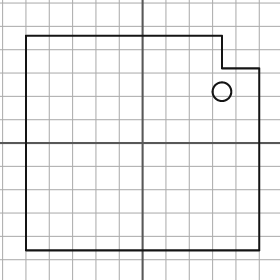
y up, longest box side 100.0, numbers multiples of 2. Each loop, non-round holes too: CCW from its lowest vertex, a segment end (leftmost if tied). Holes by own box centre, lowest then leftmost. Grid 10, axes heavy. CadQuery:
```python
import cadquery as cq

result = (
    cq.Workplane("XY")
    .moveTo(-50.0, -46.0)
    .lineTo(50.0, -46.0)
    .lineTo(50.0, 32.0)
    .lineTo(34.0, 32.0)
    .lineTo(34.0, 46.0)
    .lineTo(-50.0, 46.0)
    .close()
    .moveTo(34.0, 22.0)
    .circle(4.0)
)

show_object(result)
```